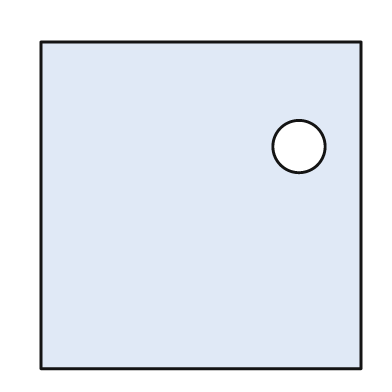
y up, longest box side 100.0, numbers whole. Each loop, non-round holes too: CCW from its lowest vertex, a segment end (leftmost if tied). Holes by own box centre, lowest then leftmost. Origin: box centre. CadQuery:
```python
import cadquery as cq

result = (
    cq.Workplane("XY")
    .moveTo(-49.0, -50.0)
    .lineTo(49.0, -50.0)
    .lineTo(49.0, 50.0)
    .lineTo(-49.0, 50.0)
    .close()
    .moveTo(30.0, 18.0)
    .circle(8.0)
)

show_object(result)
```